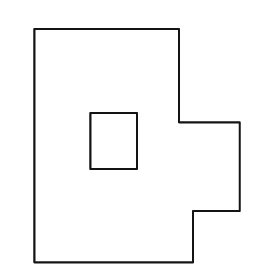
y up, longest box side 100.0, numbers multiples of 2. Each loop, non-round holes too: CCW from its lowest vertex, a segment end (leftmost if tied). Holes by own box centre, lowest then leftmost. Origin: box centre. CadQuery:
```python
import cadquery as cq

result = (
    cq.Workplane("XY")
    .moveTo(-44.0, -50.0)
    .lineTo(24.0, -50.0)
    .lineTo(24.0, -28.0)
    .lineTo(44.0, -28.0)
    .lineTo(44.0, 10.0)
    .lineTo(18.0, 10.0)
    .lineTo(18.0, 50.0)
    .lineTo(-44.0, 50.0)
    .close()
    .moveTo(-20.0, -10.0)
    .lineTo(0.0, -10.0)
    .lineTo(0.0, 14.0)
    .lineTo(-20.0, 14.0)
    .close()
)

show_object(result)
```